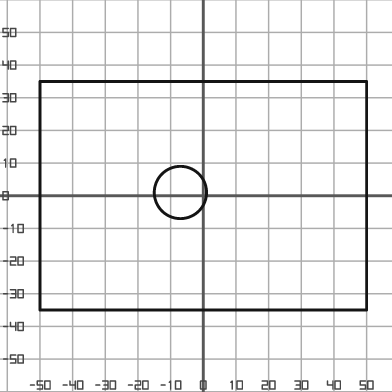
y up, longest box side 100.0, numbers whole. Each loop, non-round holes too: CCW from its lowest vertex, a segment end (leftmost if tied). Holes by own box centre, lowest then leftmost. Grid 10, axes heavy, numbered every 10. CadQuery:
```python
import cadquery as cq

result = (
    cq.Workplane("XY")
    .moveTo(-50.0, -35.0)
    .lineTo(50.0, -35.0)
    .lineTo(50.0, 35.0)
    .lineTo(-50.0, 35.0)
    .close()
    .moveTo(-7.0, 1.0)
    .circle(8.0)
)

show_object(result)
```